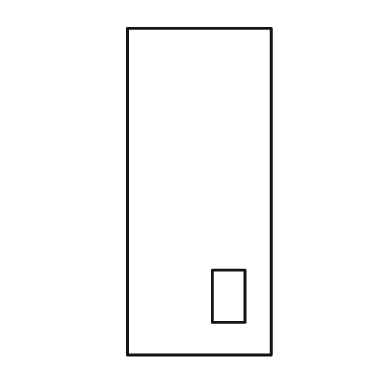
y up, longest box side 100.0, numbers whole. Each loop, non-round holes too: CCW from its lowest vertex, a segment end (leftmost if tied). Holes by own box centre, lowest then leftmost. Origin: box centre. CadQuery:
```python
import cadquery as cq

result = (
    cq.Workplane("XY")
    .moveTo(-22.0, -50.0)
    .lineTo(22.0, -50.0)
    .lineTo(22.0, 50.0)
    .lineTo(-22.0, 50.0)
    .close()
    .moveTo(4.0, -40.0)
    .lineTo(14.0, -40.0)
    .lineTo(14.0, -24.0)
    .lineTo(4.0, -24.0)
    .close()
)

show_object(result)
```